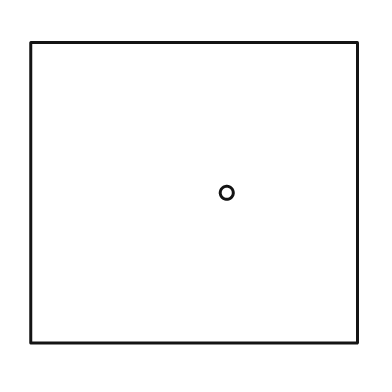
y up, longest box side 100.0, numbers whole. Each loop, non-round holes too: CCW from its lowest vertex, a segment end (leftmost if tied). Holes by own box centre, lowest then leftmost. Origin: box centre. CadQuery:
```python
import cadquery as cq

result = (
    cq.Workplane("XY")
    .moveTo(-50.0, -46.0)
    .lineTo(50.0, -46.0)
    .lineTo(50.0, 46.0)
    .lineTo(-50.0, 46.0)
    .close()
    .moveTo(10.0, 0.0)
    .circle(2.0)
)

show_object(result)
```